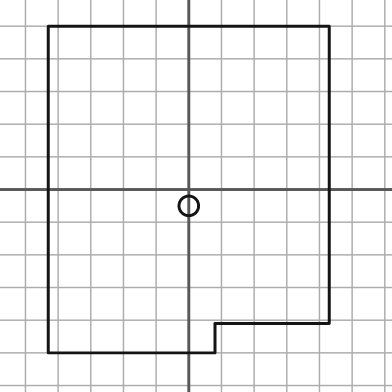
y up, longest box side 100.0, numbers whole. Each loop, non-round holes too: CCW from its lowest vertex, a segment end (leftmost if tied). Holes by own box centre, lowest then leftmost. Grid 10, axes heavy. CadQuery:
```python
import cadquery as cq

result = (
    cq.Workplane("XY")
    .moveTo(-43.0, -50.0)
    .lineTo(8.0, -50.0)
    .lineTo(8.0, -41.0)
    .lineTo(43.0, -41.0)
    .lineTo(43.0, 50.0)
    .lineTo(-43.0, 50.0)
    .close()
    .moveTo(0.0, -5.0)
    .circle(3.0)
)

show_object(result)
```